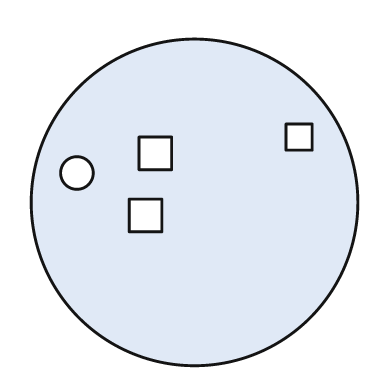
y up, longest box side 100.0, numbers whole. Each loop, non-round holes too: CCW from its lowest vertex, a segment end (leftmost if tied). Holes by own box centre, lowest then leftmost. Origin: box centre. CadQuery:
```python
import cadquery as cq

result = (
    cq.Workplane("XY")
    .moveTo(0.0, 0.0)
    .circle(50.0)
    .moveTo(-20.0, -9.0)
    .lineTo(-10.0, -9.0)
    .lineTo(-10.0, 1.0)
    .lineTo(-20.0, 1.0)
    .close()
    .moveTo(-36.0, 9.0)
    .circle(5.0)
    .moveTo(-17.0, 10.0)
    .lineTo(-7.0, 10.0)
    .lineTo(-7.0, 20.0)
    .lineTo(-17.0, 20.0)
    .close()
    .moveTo(28.0, 16.0)
    .lineTo(36.0, 16.0)
    .lineTo(36.0, 24.0)
    .lineTo(28.0, 24.0)
    .close()
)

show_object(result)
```